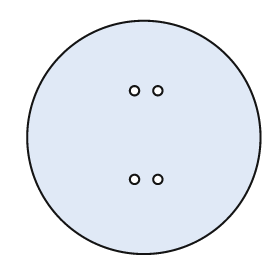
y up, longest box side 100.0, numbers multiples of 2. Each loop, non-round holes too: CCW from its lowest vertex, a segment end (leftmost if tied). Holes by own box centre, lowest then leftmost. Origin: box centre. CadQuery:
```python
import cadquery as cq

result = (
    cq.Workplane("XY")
    .moveTo(0.0, 0.0)
    .circle(50.0)
    .moveTo(-4.0, -18.0)
    .circle(2.0)
    .moveTo(6.0, -18.0)
    .circle(2.0)
    .moveTo(-4.0, 20.0)
    .circle(2.0)
    .moveTo(6.0, 20.0)
    .circle(2.0)
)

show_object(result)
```